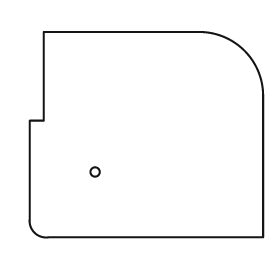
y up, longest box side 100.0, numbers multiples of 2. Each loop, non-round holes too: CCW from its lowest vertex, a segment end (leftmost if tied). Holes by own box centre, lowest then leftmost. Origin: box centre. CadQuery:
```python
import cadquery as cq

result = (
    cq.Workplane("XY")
    .moveTo(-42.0, -44.0)
    .lineTo(50.0, -44.0)
    .lineTo(50.0, 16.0)
    .threePointArc((42.0, 36.0), (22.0, 44.0))
    .lineTo(-44.0, 44.0)
    .lineTo(-44.0, 6.0)
    .lineTo(-50.0, 6.0)
    .lineTo(-50.0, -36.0)
    .threePointArc((-48.0, -42.0), (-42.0, -44.0))
    .close()
    .moveTo(-22.0, -16.0)
    .circle(2.0)
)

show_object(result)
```